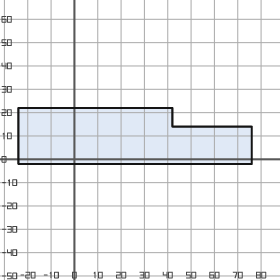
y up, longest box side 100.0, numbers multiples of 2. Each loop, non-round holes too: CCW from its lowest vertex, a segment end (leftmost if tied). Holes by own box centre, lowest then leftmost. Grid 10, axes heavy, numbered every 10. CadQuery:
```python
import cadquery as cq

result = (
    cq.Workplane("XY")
    .moveTo(-24.0, -2.0)
    .lineTo(76.0, -2.0)
    .lineTo(76.0, 14.0)
    .lineTo(42.0, 14.0)
    .lineTo(42.0, 22.0)
    .lineTo(-24.0, 22.0)
    .close()
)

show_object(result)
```